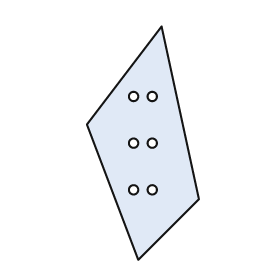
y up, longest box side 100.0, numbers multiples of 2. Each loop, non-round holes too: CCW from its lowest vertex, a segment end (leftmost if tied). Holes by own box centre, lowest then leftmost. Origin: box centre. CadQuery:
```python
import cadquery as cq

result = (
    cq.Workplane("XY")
    .moveTo(-2.0, -50.0)
    .lineTo(24.0, -24.0)
    .lineTo(8.0, 50.0)
    .lineTo(-24.0, 8.0)
    .close()
    .moveTo(-4.0, -20.0)
    .circle(2.0)
    .moveTo(4.0, -20.0)
    .circle(2.0)
    .moveTo(-4.0, 0.0)
    .circle(2.0)
    .moveTo(4.0, 0.0)
    .circle(2.0)
    .moveTo(-4.0, 20.0)
    .circle(2.0)
    .moveTo(4.0, 20.0)
    .circle(2.0)
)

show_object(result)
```